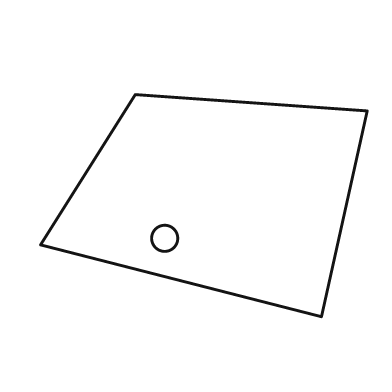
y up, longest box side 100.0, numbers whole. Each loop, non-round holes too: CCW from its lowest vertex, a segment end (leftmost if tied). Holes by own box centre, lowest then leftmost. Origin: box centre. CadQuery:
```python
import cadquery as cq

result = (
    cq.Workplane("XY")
    .moveTo(36.0, -34.0)
    .lineTo(50.0, 29.0)
    .lineTo(-21.0, 34.0)
    .lineTo(-50.0, -12.0)
    .close()
    .moveTo(-12.0, -10.0)
    .circle(4.0)
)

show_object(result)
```